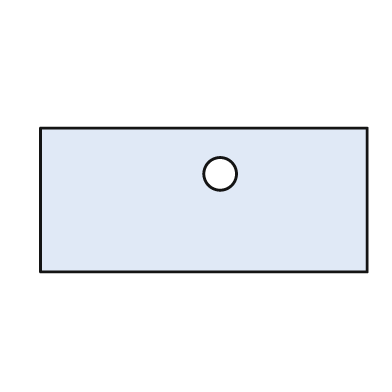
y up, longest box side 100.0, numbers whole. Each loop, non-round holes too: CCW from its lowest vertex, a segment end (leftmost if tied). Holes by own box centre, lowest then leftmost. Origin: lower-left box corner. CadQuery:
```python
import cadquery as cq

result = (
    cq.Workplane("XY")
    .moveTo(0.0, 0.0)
    .lineTo(100.0, 0.0)
    .lineTo(100.0, 44.0)
    .lineTo(0.0, 44.0)
    .close()
    .moveTo(55.0, 30.0)
    .circle(5.0)
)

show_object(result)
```